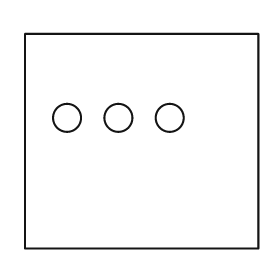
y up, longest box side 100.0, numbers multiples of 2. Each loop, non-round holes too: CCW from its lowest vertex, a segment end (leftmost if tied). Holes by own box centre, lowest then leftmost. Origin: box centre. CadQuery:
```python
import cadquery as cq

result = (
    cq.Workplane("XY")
    .moveTo(-50.0, -46.0)
    .lineTo(50.0, -46.0)
    .lineTo(50.0, 46.0)
    .lineTo(-50.0, 46.0)
    .close()
    .moveTo(-32.0, 10.0)
    .circle(6.0)
    .moveTo(-10.0, 10.0)
    .circle(6.0)
    .moveTo(12.0, 10.0)
    .circle(6.0)
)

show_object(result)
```